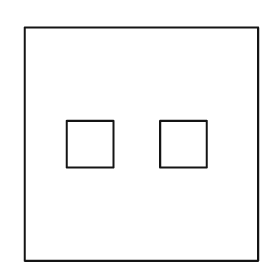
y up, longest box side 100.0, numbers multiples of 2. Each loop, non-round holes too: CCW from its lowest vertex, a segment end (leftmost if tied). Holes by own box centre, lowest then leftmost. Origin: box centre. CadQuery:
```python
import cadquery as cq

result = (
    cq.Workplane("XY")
    .moveTo(-50.0, -50.0)
    .lineTo(50.0, -50.0)
    .lineTo(50.0, 50.0)
    .lineTo(-50.0, 50.0)
    .close()
    .moveTo(-32.0, -10.0)
    .lineTo(-12.0, -10.0)
    .lineTo(-12.0, 10.0)
    .lineTo(-32.0, 10.0)
    .close()
    .moveTo(8.0, -10.0)
    .lineTo(28.0, -10.0)
    .lineTo(28.0, 10.0)
    .lineTo(8.0, 10.0)
    .close()
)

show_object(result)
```